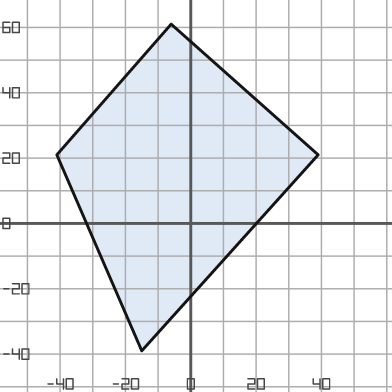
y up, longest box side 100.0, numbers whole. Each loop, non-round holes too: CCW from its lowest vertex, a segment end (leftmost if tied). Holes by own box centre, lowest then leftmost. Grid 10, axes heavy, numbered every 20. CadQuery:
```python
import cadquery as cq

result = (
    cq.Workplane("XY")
    .moveTo(-15.0, -39.0)
    .lineTo(39.0, 21.0)
    .lineTo(-6.0, 61.0)
    .lineTo(-41.0, 21.0)
    .close()
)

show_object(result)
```